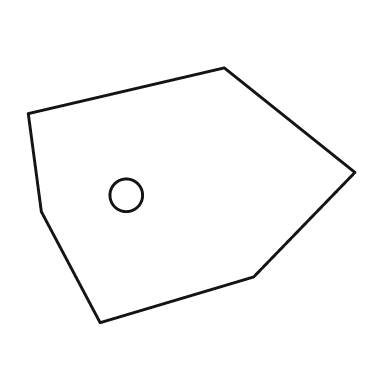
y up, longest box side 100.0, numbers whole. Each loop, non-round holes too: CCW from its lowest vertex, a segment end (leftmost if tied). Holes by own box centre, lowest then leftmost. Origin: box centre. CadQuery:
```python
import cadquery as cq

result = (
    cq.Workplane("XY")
    .moveTo(-28.0, -39.0)
    .lineTo(19.0, -25.0)
    .lineTo(50.0, 7.0)
    .lineTo(10.0, 39.0)
    .lineTo(-50.0, 25.0)
    .lineTo(-46.0, -5.0)
    .close()
    .moveTo(-20.0, 0.0)
    .circle(5.0)
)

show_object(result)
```